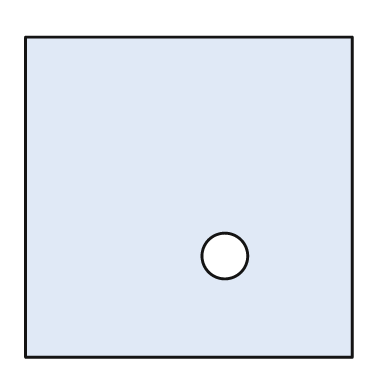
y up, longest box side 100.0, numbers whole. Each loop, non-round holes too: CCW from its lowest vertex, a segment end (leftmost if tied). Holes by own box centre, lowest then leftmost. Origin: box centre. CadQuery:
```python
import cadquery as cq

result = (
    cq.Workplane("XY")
    .moveTo(-50.0, -49.0)
    .lineTo(50.0, -49.0)
    .lineTo(50.0, 49.0)
    .lineTo(-50.0, 49.0)
    .close()
    .moveTo(11.0, -18.0)
    .circle(7.0)
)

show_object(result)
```